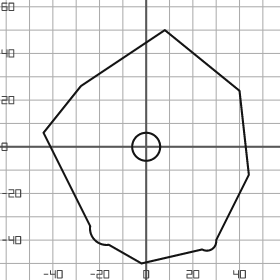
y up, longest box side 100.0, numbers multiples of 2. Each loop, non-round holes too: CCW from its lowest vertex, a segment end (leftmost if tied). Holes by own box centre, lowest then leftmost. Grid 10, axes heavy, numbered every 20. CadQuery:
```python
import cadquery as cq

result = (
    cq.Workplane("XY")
    .moveTo(-2.0, -50.0)
    .lineTo(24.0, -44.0)
    .threePointArc((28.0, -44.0), (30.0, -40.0))
    .lineTo(44.0, -12.0)
    .lineTo(40.0, 24.0)
    .lineTo(8.0, 50.0)
    .lineTo(-28.0, 26.0)
    .lineTo(-44.0, 6.0)
    .lineTo(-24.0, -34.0)
    .threePointArc((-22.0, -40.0), (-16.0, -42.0))
    .close()
    .moveTo(0.0, 0.0)
    .circle(6.0)
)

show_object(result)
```